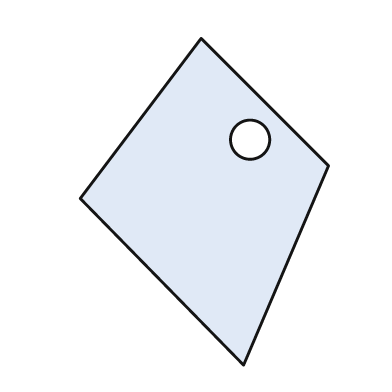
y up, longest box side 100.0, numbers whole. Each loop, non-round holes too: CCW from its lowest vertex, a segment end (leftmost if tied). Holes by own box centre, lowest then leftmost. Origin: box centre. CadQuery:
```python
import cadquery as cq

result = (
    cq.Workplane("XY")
    .moveTo(12.0, -50.0)
    .lineTo(38.0, 11.0)
    .lineTo(-1.0, 50.0)
    .lineTo(-38.0, 1.0)
    .close()
    .moveTo(14.0, 19.0)
    .circle(6.0)
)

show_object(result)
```